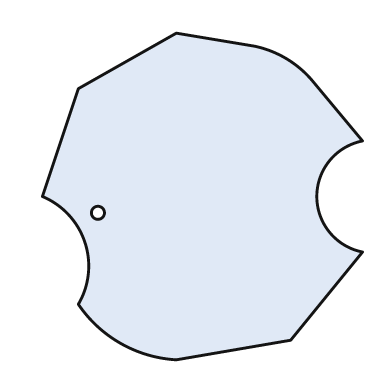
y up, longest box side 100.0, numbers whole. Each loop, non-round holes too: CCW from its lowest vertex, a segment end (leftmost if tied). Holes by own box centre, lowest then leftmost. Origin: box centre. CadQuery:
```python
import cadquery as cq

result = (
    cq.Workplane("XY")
    .moveTo(-8.0, -50.0)
    .lineTo(27.0, -44.0)
    .lineTo(49.0, -17.0)
    .threePointArc((35.0, 0.0), (49.0, 17.0))
    .lineTo(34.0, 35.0)
    .threePointArc((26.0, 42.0), (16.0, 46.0))
    .lineTo(-8.0, 50.0)
    .lineTo(-38.0, 33.0)
    .lineTo(-49.0, 0.0)
    .threePointArc((-36.0, -14.0), (-38.0, -33.0))
    .threePointArc((-25.0, -45.0), (-8.0, -50.0))
    .close()
    .moveTo(-32.0, -5.0)
    .circle(2.0)
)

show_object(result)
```